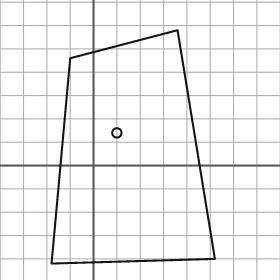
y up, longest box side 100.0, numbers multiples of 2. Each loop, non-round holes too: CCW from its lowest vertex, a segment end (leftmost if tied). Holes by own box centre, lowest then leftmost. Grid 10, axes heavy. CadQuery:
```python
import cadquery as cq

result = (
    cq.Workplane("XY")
    .moveTo(-18.0, -42.0)
    .lineTo(52.0, -40.0)
    .lineTo(36.0, 58.0)
    .lineTo(-10.0, 46.0)
    .close()
    .moveTo(10.0, 14.0)
    .circle(2.0)
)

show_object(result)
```